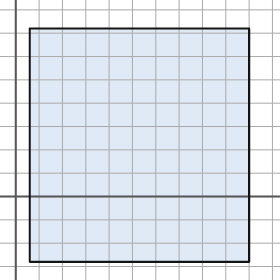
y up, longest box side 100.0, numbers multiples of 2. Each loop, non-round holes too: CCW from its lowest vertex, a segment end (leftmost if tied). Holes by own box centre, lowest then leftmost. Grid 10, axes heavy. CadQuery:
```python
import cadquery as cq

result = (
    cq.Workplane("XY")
    .moveTo(6.0, -28.0)
    .lineTo(100.0, -28.0)
    .lineTo(100.0, 72.0)
    .lineTo(6.0, 72.0)
    .close()
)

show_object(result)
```